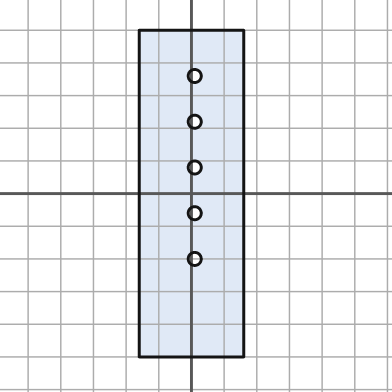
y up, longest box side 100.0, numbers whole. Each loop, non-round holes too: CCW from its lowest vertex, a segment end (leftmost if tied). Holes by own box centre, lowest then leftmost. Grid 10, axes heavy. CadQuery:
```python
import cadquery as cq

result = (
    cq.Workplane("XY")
    .moveTo(-16.0, -50.0)
    .lineTo(16.0, -50.0)
    .lineTo(16.0, 50.0)
    .lineTo(-16.0, 50.0)
    .close()
    .moveTo(1.0, -20.0)
    .circle(2.0)
    .moveTo(1.0, -6.0)
    .circle(2.0)
    .moveTo(1.0, 8.0)
    .circle(2.0)
    .moveTo(1.0, 22.0)
    .circle(2.0)
    .moveTo(1.0, 36.0)
    .circle(2.0)
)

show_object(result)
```